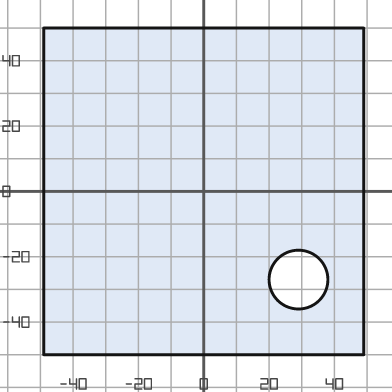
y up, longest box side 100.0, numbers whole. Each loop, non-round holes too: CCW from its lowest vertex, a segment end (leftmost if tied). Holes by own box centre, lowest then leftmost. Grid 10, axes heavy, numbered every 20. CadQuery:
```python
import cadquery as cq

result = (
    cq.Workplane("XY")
    .moveTo(-49.0, -50.0)
    .lineTo(49.0, -50.0)
    .lineTo(49.0, 50.0)
    .lineTo(-49.0, 50.0)
    .close()
    .moveTo(29.0, -27.0)
    .circle(9.0)
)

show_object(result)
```